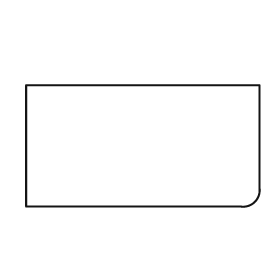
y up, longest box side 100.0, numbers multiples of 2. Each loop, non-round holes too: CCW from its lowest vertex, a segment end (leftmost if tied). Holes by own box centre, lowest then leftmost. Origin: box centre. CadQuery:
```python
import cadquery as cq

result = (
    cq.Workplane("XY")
    .moveTo(-50.0, -26.0)
    .lineTo(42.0, -26.0)
    .threePointArc((48.0, -24.0), (50.0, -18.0))
    .lineTo(50.0, 26.0)
    .lineTo(-50.0, 26.0)
    .close()
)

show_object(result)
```